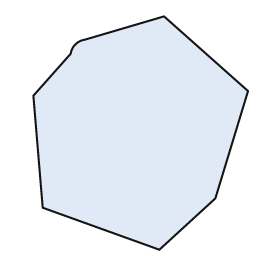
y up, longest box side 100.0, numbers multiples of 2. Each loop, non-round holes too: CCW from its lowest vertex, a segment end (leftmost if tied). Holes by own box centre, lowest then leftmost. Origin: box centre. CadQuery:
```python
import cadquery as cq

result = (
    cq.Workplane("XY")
    .moveTo(8.0, -50.0)
    .lineTo(32.0, -28.0)
    .lineTo(46.0, 18.0)
    .lineTo(10.0, 50.0)
    .lineTo(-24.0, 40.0)
    .threePointArc((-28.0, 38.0), (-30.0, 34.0))
    .lineTo(-46.0, 16.0)
    .lineTo(-42.0, -32.0)
    .close()
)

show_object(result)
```